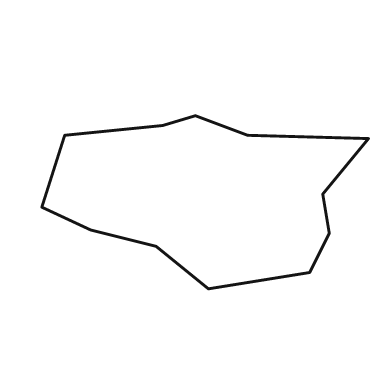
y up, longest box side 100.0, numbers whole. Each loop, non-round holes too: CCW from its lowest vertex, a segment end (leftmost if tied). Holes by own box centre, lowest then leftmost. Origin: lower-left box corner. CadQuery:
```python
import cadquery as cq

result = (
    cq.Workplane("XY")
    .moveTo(51.0, 0.0)
    .lineTo(82.0, 5.0)
    .lineTo(88.0, 17.0)
    .lineTo(86.0, 29.0)
    .lineTo(100.0, 46.0)
    .lineTo(63.0, 47.0)
    .lineTo(47.0, 53.0)
    .lineTo(37.0, 50.0)
    .lineTo(7.0, 47.0)
    .lineTo(0.0, 25.0)
    .lineTo(15.0, 18.0)
    .lineTo(35.0, 13.0)
    .close()
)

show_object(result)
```